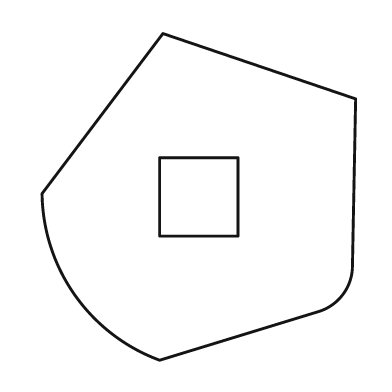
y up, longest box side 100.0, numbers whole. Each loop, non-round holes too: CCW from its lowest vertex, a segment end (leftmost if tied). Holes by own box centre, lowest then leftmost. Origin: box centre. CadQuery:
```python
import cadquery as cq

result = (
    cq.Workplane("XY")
    .moveTo(-12.0, -50.0)
    .lineTo(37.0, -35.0)
    .threePointArc((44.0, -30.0), (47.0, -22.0))
    .lineTo(48.0, 30.0)
    .lineTo(-11.0, 50.0)
    .lineTo(-48.0, 1.0)
    .threePointArc((-38.0, -30.0), (-12.0, -50.0))
    .close()
    .moveTo(-12.0, -12.0)
    .lineTo(12.0, -12.0)
    .lineTo(12.0, 12.0)
    .lineTo(-12.0, 12.0)
    .close()
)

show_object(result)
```